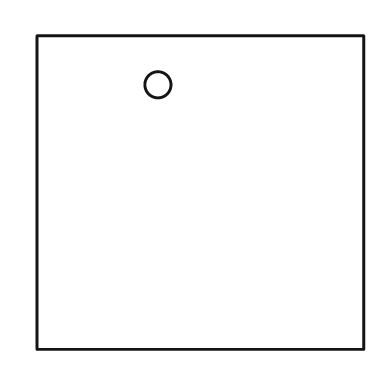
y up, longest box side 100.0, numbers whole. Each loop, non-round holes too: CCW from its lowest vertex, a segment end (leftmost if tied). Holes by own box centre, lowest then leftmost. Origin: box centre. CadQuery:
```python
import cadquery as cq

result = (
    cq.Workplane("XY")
    .moveTo(-50.0, -48.0)
    .lineTo(50.0, -48.0)
    .lineTo(50.0, 48.0)
    .lineTo(-50.0, 48.0)
    .close()
    .moveTo(-13.0, 33.0)
    .circle(4.0)
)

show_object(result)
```